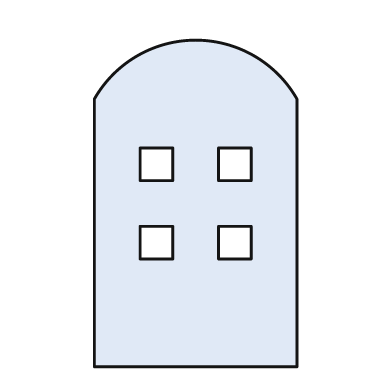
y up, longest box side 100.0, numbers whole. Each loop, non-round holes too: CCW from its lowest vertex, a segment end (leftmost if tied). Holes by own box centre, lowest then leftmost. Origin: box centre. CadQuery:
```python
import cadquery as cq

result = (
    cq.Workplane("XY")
    .moveTo(-31.0, -50.0)
    .lineTo(31.0, -50.0)
    .lineTo(31.0, 32.0)
    .threePointArc((0.0, 50.0), (-31.0, 32.0))
    .close()
    .moveTo(-17.0, -17.0)
    .lineTo(-7.0, -17.0)
    .lineTo(-7.0, -7.0)
    .lineTo(-17.0, -7.0)
    .close()
    .moveTo(7.0, -17.0)
    .lineTo(17.0, -17.0)
    .lineTo(17.0, -7.0)
    .lineTo(7.0, -7.0)
    .close()
    .moveTo(-17.0, 7.0)
    .lineTo(-7.0, 7.0)
    .lineTo(-7.0, 17.0)
    .lineTo(-17.0, 17.0)
    .close()
    .moveTo(7.0, 7.0)
    .lineTo(17.0, 7.0)
    .lineTo(17.0, 17.0)
    .lineTo(7.0, 17.0)
    .close()
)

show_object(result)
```